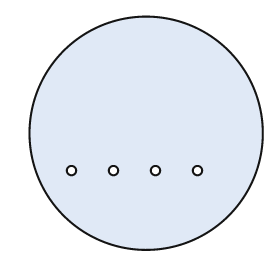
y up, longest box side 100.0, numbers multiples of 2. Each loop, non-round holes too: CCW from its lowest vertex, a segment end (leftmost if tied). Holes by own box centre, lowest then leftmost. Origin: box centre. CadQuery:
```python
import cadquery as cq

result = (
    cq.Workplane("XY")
    .moveTo(0.0, 0.0)
    .circle(50.0)
    .moveTo(-32.0, -16.0)
    .circle(2.0)
    .moveTo(-14.0, -16.0)
    .circle(2.0)
    .moveTo(4.0, -16.0)
    .circle(2.0)
    .moveTo(22.0, -16.0)
    .circle(2.0)
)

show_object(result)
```